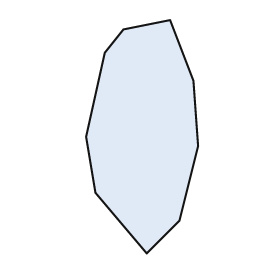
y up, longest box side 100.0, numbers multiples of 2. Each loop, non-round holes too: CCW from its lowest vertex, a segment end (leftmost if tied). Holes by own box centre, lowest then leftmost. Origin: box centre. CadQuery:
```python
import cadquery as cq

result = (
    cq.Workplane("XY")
    .moveTo(2.0, -50.0)
    .lineTo(16.0, -36.0)
    .lineTo(24.0, -4.0)
    .lineTo(22.0, 24.0)
    .lineTo(12.0, 50.0)
    .lineTo(-8.0, 46.0)
    .lineTo(-16.0, 36.0)
    .lineTo(-24.0, 0.0)
    .lineTo(-20.0, -24.0)
    .close()
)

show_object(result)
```